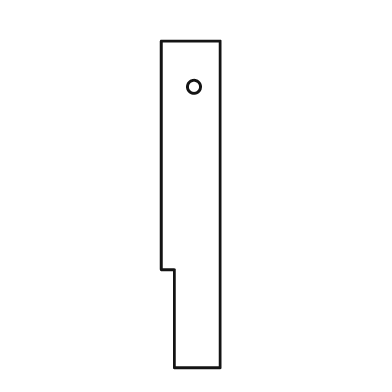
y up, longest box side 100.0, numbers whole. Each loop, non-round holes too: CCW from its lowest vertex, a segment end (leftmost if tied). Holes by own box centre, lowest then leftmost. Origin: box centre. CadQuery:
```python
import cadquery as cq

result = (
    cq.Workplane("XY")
    .moveTo(-5.0, -50.0)
    .lineTo(9.0, -50.0)
    .lineTo(9.0, 50.0)
    .lineTo(-9.0, 50.0)
    .lineTo(-9.0, -20.0)
    .lineTo(-5.0, -20.0)
    .close()
    .moveTo(1.0, 36.0)
    .circle(2.0)
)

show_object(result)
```